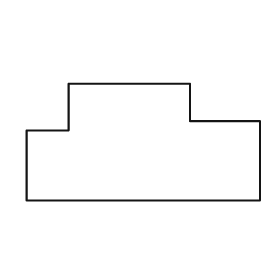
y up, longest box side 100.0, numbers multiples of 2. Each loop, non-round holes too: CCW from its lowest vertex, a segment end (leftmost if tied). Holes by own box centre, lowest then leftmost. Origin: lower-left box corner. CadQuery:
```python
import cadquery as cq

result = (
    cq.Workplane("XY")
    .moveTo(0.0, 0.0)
    .lineTo(100.0, 0.0)
    .lineTo(100.0, 34.0)
    .lineTo(70.0, 34.0)
    .lineTo(70.0, 50.0)
    .lineTo(18.0, 50.0)
    .lineTo(18.0, 30.0)
    .lineTo(0.0, 30.0)
    .close()
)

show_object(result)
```